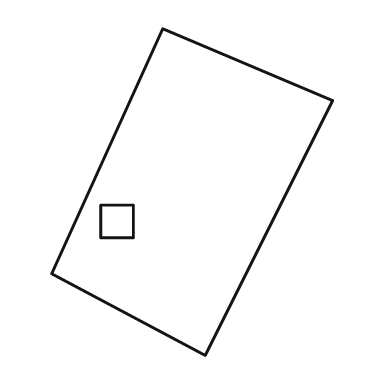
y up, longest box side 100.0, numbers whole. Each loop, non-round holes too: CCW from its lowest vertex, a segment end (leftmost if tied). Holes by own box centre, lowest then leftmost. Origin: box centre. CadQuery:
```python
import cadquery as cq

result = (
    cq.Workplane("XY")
    .moveTo(4.0, -50.0)
    .lineTo(43.0, 28.0)
    .lineTo(-9.0, 50.0)
    .lineTo(-43.0, -25.0)
    .close()
    .moveTo(-28.0, -14.0)
    .lineTo(-18.0, -14.0)
    .lineTo(-18.0, -4.0)
    .lineTo(-28.0, -4.0)
    .close()
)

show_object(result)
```